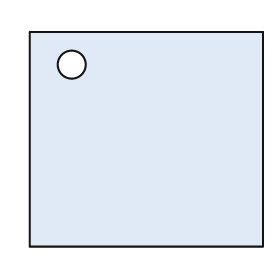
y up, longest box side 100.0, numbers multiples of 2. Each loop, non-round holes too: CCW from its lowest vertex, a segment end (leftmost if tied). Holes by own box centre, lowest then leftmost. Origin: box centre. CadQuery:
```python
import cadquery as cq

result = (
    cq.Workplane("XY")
    .moveTo(-50.0, -46.0)
    .lineTo(50.0, -46.0)
    .lineTo(50.0, 46.0)
    .lineTo(-50.0, 46.0)
    .close()
    .moveTo(-32.0, 32.0)
    .circle(6.0)
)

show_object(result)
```